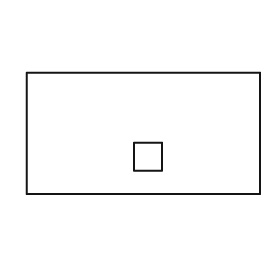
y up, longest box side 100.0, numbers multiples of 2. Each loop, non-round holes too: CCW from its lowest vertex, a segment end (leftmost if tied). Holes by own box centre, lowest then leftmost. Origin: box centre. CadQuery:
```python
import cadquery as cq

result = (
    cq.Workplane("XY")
    .moveTo(-50.0, -26.0)
    .lineTo(50.0, -26.0)
    .lineTo(50.0, 26.0)
    .lineTo(-50.0, 26.0)
    .close()
    .moveTo(-4.0, -16.0)
    .lineTo(8.0, -16.0)
    .lineTo(8.0, -4.0)
    .lineTo(-4.0, -4.0)
    .close()
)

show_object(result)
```